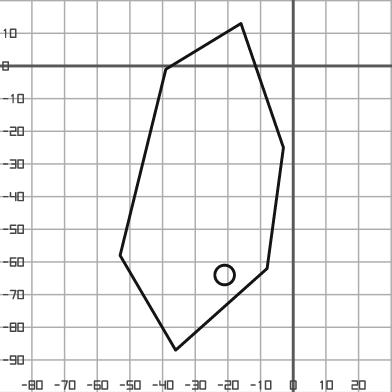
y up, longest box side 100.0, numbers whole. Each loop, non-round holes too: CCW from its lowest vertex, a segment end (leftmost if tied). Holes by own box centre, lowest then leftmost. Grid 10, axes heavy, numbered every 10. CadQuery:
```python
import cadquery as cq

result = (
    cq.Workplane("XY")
    .moveTo(-36.0, -87.0)
    .lineTo(-8.0, -62.0)
    .lineTo(-3.0, -25.0)
    .lineTo(-16.0, 13.0)
    .lineTo(-39.0, -1.0)
    .lineTo(-53.0, -58.0)
    .close()
    .moveTo(-21.0, -64.0)
    .circle(3.0)
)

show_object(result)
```